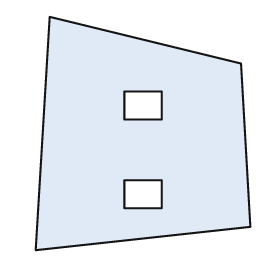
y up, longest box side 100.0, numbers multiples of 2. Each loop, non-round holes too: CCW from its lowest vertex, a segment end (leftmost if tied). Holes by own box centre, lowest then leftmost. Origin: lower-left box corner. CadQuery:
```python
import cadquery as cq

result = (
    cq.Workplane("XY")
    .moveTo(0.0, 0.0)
    .lineTo(92.0, 10.0)
    .lineTo(88.0, 80.0)
    .lineTo(6.0, 100.0)
    .close()
    .moveTo(38.0, 18.0)
    .lineTo(54.0, 18.0)
    .lineTo(54.0, 30.0)
    .lineTo(38.0, 30.0)
    .close()
    .moveTo(38.0, 56.0)
    .lineTo(54.0, 56.0)
    .lineTo(54.0, 68.0)
    .lineTo(38.0, 68.0)
    .close()
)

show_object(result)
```